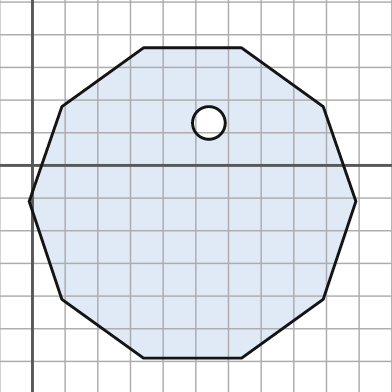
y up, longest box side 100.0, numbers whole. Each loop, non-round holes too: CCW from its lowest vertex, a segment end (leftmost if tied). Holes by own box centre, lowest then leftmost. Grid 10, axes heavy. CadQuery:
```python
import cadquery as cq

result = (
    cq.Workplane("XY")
    .moveTo(34.0, -59.0)
    .lineTo(64.0, -59.0)
    .lineTo(89.0, -41.0)
    .lineTo(99.0, -11.0)
    .lineTo(89.0, 18.0)
    .lineTo(64.0, 36.0)
    .lineTo(34.0, 36.0)
    .lineTo(9.0, 18.0)
    .lineTo(-1.0, -11.0)
    .lineTo(9.0, -41.0)
    .close()
    .moveTo(54.0, 13.0)
    .circle(5.0)
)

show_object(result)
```